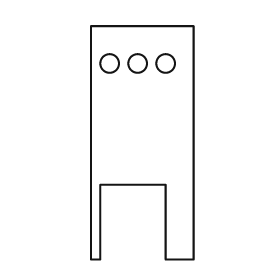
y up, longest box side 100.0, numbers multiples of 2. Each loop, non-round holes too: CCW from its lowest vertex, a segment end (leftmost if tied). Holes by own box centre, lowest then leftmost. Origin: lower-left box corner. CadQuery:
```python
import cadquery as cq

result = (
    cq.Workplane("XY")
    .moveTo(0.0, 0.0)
    .lineTo(4.0, 0.0)
    .lineTo(4.0, 32.0)
    .lineTo(32.0, 32.0)
    .lineTo(32.0, 0.0)
    .lineTo(44.0, 0.0)
    .lineTo(44.0, 100.0)
    .lineTo(0.0, 100.0)
    .close()
    .moveTo(8.0, 84.0)
    .circle(4.0)
    .moveTo(20.0, 84.0)
    .circle(4.0)
    .moveTo(32.0, 84.0)
    .circle(4.0)
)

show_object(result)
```